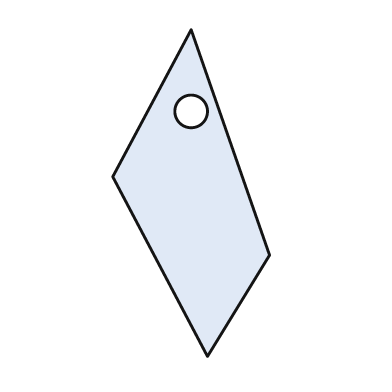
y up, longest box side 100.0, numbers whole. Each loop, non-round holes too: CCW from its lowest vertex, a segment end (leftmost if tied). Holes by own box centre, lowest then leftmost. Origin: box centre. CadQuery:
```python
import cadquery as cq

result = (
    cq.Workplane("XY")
    .moveTo(5.0, -50.0)
    .lineTo(24.0, -19.0)
    .lineTo(0.0, 50.0)
    .lineTo(-24.0, 5.0)
    .close()
    .moveTo(0.0, 25.0)
    .circle(5.0)
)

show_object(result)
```